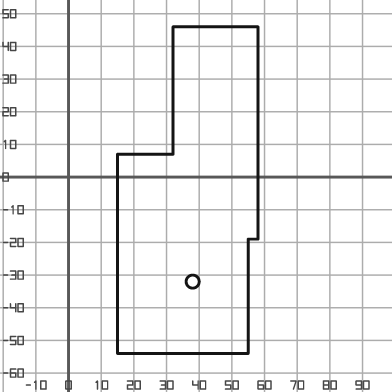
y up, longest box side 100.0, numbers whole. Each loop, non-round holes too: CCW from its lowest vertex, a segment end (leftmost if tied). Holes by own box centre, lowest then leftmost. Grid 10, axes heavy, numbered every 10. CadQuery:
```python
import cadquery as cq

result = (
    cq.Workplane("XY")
    .moveTo(15.0, -54.0)
    .lineTo(55.0, -54.0)
    .lineTo(55.0, -19.0)
    .lineTo(58.0, -19.0)
    .lineTo(58.0, 46.0)
    .lineTo(32.0, 46.0)
    .lineTo(32.0, 7.0)
    .lineTo(15.0, 7.0)
    .close()
    .moveTo(38.0, -32.0)
    .circle(2.0)
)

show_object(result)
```